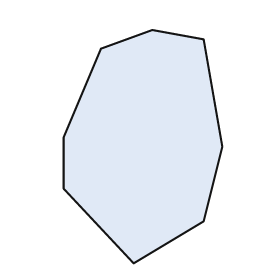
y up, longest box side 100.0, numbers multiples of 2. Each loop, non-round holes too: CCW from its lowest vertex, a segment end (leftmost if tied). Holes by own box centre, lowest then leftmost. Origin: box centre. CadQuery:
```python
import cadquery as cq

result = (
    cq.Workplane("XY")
    .moveTo(-4.0, -50.0)
    .lineTo(26.0, -32.0)
    .lineTo(34.0, 0.0)
    .lineTo(26.0, 46.0)
    .lineTo(4.0, 50.0)
    .lineTo(-18.0, 42.0)
    .lineTo(-34.0, 4.0)
    .lineTo(-34.0, -18.0)
    .close()
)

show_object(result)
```